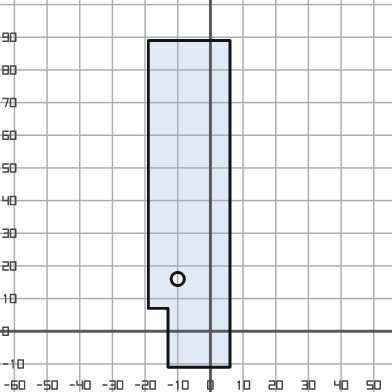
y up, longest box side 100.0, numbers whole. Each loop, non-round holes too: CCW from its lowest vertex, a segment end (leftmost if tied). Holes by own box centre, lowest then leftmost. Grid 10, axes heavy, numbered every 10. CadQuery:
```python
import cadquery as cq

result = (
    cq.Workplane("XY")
    .moveTo(-13.0, -11.0)
    .lineTo(6.0, -11.0)
    .lineTo(6.0, 89.0)
    .lineTo(-19.0, 89.0)
    .lineTo(-19.0, 7.0)
    .lineTo(-13.0, 7.0)
    .close()
    .moveTo(-10.0, 16.0)
    .circle(2.0)
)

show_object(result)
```